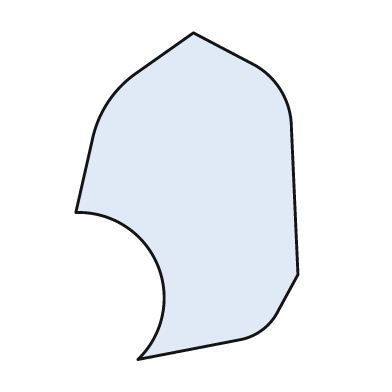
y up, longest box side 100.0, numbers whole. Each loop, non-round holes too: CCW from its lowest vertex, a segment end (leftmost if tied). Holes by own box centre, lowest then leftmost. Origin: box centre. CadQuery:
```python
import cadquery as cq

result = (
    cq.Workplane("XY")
    .moveTo(-15.0, -50.0)
    .lineTo(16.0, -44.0)
    .threePointArc((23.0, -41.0), (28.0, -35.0))
    .lineTo(34.0, -24.0)
    .lineTo(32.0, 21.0)
    .threePointArc((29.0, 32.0), (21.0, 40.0))
    .lineTo(2.0, 50.0)
    .lineTo(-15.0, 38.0)
    .threePointArc((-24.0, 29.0), (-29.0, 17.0))
    .lineTo(-34.0, -5.0)
    .threePointArc((-9.0, -21.0), (-15.0, -50.0))
    .close()
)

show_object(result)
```